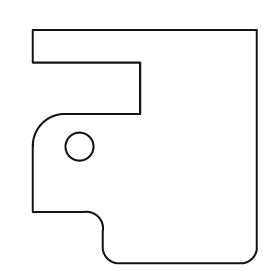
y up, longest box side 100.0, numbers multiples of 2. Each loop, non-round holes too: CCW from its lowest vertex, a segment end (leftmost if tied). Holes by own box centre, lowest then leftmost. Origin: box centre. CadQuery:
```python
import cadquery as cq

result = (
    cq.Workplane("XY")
    .moveTo(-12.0, -50.0)
    .lineTo(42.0, -50.0)
    .threePointArc((46.0, -48.0), (48.0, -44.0))
    .lineTo(48.0, 50.0)
    .lineTo(-48.0, 50.0)
    .lineTo(-48.0, 36.0)
    .lineTo(-2.0, 36.0)
    .lineTo(-2.0, 14.0)
    .lineTo(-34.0, 14.0)
    .threePointArc((-44.0, 10.0), (-48.0, 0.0))
    .lineTo(-48.0, -28.0)
    .lineTo(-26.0, -28.0)
    .threePointArc((-20.0, -30.0), (-18.0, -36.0))
    .lineTo(-18.0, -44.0)
    .threePointArc((-16.0, -48.0), (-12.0, -50.0))
    .close()
    .moveTo(-28.0, 0.0)
    .circle(6.0)
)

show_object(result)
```